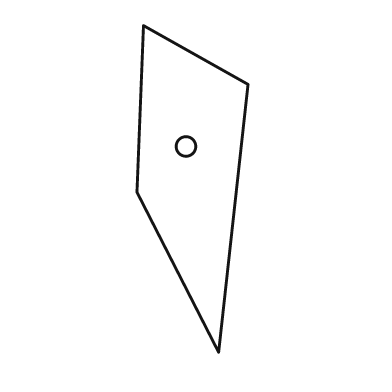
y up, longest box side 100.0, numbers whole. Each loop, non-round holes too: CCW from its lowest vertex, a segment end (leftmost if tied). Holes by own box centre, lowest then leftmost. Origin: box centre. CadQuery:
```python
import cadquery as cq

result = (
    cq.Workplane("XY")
    .moveTo(8.0, -50.0)
    .lineTo(17.0, 32.0)
    .lineTo(-15.0, 50.0)
    .lineTo(-17.0, -1.0)
    .close()
    .moveTo(-2.0, 13.0)
    .circle(3.0)
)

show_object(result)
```